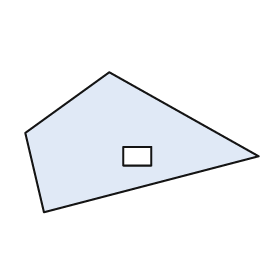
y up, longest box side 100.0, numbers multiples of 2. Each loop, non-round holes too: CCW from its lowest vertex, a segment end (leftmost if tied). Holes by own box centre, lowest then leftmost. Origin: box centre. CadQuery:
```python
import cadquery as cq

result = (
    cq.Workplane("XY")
    .moveTo(-42.0, -30.0)
    .lineTo(50.0, -6.0)
    .lineTo(-14.0, 30.0)
    .lineTo(-50.0, 4.0)
    .close()
    .moveTo(-8.0, -10.0)
    .lineTo(4.0, -10.0)
    .lineTo(4.0, -2.0)
    .lineTo(-8.0, -2.0)
    .close()
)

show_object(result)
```